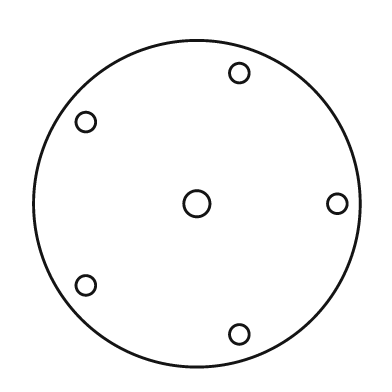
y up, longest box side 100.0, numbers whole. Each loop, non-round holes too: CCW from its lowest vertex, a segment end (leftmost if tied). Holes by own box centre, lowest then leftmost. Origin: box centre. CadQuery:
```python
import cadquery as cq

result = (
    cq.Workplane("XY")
    .moveTo(0.0, 0.0)
    .circle(50.0)
    .moveTo(13.0, -40.0)
    .circle(3.0)
    .moveTo(-34.0, -25.0)
    .circle(3.0)
    .moveTo(0.0, 0.0)
    .circle(4.0)
    .moveTo(43.0, 0.0)
    .circle(3.0)
    .moveTo(-34.0, 25.0)
    .circle(3.0)
    .moveTo(13.0, 40.0)
    .circle(3.0)
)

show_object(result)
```